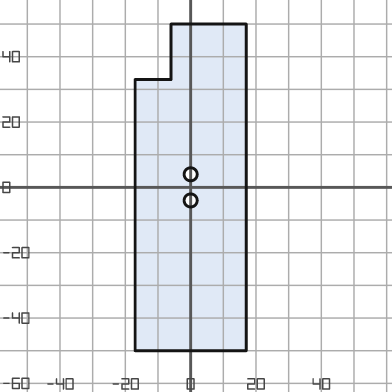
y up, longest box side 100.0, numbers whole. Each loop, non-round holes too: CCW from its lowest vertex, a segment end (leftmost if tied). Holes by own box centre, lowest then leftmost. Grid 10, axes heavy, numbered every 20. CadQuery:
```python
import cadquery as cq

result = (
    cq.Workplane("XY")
    .moveTo(-17.0, -50.0)
    .lineTo(17.0, -50.0)
    .lineTo(17.0, 50.0)
    .lineTo(-6.0, 50.0)
    .lineTo(-6.0, 33.0)
    .lineTo(-17.0, 33.0)
    .close()
    .moveTo(0.0, -4.0)
    .circle(2.0)
    .moveTo(0.0, 4.0)
    .circle(2.0)
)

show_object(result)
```